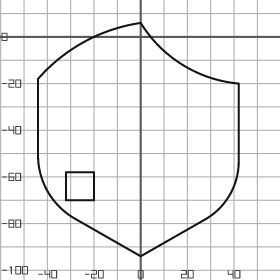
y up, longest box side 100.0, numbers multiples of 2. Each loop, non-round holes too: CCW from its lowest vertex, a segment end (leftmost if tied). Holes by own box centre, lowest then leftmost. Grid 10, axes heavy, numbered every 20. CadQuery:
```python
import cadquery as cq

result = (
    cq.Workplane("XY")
    .moveTo(0.0, -94.0)
    .lineTo(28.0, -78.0)
    .threePointArc((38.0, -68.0), (42.0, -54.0))
    .lineTo(42.0, -20.0)
    .threePointArc((18.0, -12.0), (0.0, 6.0))
    .threePointArc((-24.0, -2.0), (-44.0, -18.0))
    .lineTo(-44.0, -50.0)
    .threePointArc((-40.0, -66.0), (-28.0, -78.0))
    .close()
    .moveTo(-32.0, -70.0)
    .lineTo(-20.0, -70.0)
    .lineTo(-20.0, -58.0)
    .lineTo(-32.0, -58.0)
    .close()
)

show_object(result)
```